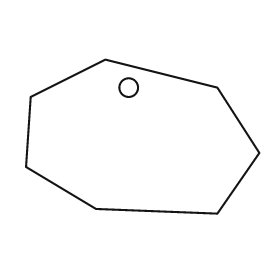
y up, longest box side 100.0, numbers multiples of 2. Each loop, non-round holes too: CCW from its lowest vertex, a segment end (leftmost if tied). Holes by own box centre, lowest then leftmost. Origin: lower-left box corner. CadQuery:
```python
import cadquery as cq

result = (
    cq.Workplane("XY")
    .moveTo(82.0, 0.0)
    .lineTo(100.0, 26.0)
    .lineTo(82.0, 54.0)
    .lineTo(34.0, 66.0)
    .lineTo(2.0, 50.0)
    .lineTo(0.0, 20.0)
    .lineTo(30.0, 2.0)
    .close()
    .moveTo(44.0, 54.0)
    .circle(4.0)
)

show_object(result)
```